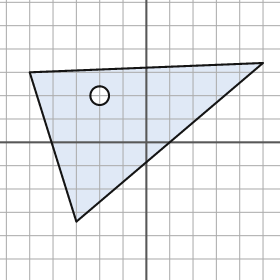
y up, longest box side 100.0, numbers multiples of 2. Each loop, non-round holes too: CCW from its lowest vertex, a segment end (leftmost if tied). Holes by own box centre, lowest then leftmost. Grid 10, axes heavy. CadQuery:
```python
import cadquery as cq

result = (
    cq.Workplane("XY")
    .moveTo(-30.0, -34.0)
    .lineTo(50.0, 34.0)
    .lineTo(-50.0, 30.0)
    .close()
    .moveTo(-20.0, 20.0)
    .circle(4.0)
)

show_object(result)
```